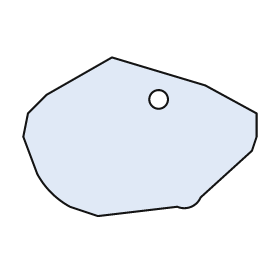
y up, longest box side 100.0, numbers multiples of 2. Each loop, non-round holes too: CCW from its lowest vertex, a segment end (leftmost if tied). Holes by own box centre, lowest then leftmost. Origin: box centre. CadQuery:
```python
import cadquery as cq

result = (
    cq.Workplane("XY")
    .moveTo(-18.0, -34.0)
    .lineTo(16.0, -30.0)
    .threePointArc((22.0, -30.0), (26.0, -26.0))
    .lineTo(48.0, -6.0)
    .lineTo(50.0, 0.0)
    .lineTo(50.0, 10.0)
    .lineTo(28.0, 22.0)
    .lineTo(-12.0, 34.0)
    .lineTo(-40.0, 18.0)
    .lineTo(-48.0, 10.0)
    .lineTo(-50.0, 0.0)
    .lineTo(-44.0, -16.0)
    .threePointArc((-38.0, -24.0), (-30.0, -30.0))
    .close()
    .moveTo(8.0, 16.0)
    .circle(4.0)
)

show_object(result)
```